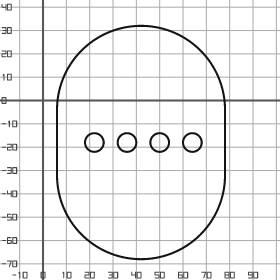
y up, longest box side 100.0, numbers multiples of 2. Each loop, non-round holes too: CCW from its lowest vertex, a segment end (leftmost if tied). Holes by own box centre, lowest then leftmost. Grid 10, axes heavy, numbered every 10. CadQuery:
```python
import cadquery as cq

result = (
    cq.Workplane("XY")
    .moveTo(6.0, -32.0)
    .threePointArc((42.0, -68.0), (78.0, -32.0))
    .lineTo(78.0, -4.0)
    .threePointArc((42.0, 32.0), (6.0, -4.0))
    .close()
    .moveTo(22.0, -18.0)
    .circle(4.0)
    .moveTo(36.0, -18.0)
    .circle(4.0)
    .moveTo(50.0, -18.0)
    .circle(4.0)
    .moveTo(64.0, -18.0)
    .circle(4.0)
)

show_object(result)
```